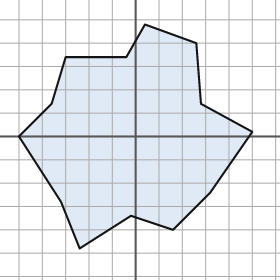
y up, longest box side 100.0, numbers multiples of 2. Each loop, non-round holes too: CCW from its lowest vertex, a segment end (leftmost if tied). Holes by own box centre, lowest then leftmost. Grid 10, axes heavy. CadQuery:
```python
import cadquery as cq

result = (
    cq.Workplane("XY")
    .moveTo(-24.0, -48.0)
    .lineTo(-2.0, -34.0)
    .lineTo(16.0, -40.0)
    .lineTo(32.0, -24.0)
    .lineTo(50.0, 2.0)
    .lineTo(28.0, 14.0)
    .lineTo(26.0, 40.0)
    .lineTo(4.0, 48.0)
    .lineTo(-4.0, 34.0)
    .lineTo(-30.0, 34.0)
    .lineTo(-36.0, 14.0)
    .lineTo(-50.0, 0.0)
    .lineTo(-32.0, -28.0)
    .close()
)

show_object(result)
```